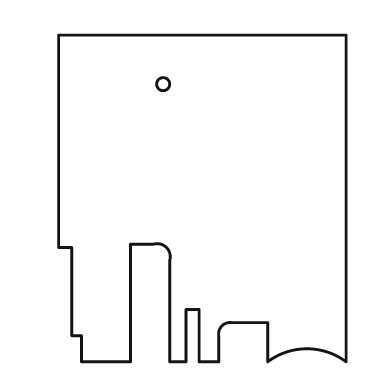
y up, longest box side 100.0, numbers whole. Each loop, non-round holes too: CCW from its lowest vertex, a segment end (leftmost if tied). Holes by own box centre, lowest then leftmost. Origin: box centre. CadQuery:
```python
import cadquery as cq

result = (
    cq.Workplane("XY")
    .moveTo(-37.0, -50.0)
    .lineTo(-22.0, -50.0)
    .lineTo(-22.0, -14.0)
    .lineTo(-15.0, -14.0)
    .threePointArc((-11.0, -15.0), (-10.0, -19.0))
    .lineTo(-10.0, -50.0)
    .lineTo(-5.0, -50.0)
    .lineTo(-5.0, -34.0)
    .lineTo(-1.0, -34.0)
    .lineTo(-1.0, -50.0)
    .lineTo(5.0, -50.0)
    .lineTo(5.0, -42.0)
    .threePointArc((6.0, -39.0), (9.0, -38.0))
    .lineTo(20.0, -38.0)
    .lineTo(20.0, -50.0)
    .threePointArc((32.0, -46.0), (44.0, -50.0))
    .lineTo(44.0, 50.0)
    .lineTo(-44.0, 50.0)
    .lineTo(-44.0, -15.0)
    .lineTo(-40.0, -15.0)
    .lineTo(-40.0, -42.0)
    .lineTo(-37.0, -42.0)
    .close()
    .moveTo(-12.0, 35.0)
    .circle(2.0)
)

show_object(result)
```